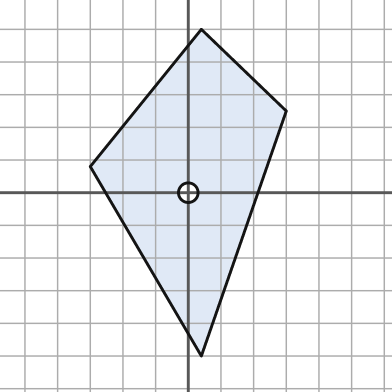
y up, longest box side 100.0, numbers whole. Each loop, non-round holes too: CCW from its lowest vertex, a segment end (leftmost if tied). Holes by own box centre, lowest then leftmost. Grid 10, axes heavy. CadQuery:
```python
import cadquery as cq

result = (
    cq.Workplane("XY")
    .moveTo(4.0, -50.0)
    .lineTo(30.0, 25.0)
    .lineTo(4.0, 50.0)
    .lineTo(-30.0, 8.0)
    .close()
    .moveTo(0.0, 0.0)
    .circle(3.0)
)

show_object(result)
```